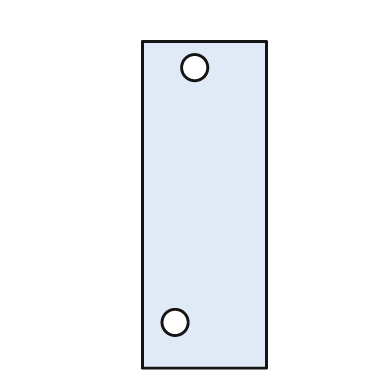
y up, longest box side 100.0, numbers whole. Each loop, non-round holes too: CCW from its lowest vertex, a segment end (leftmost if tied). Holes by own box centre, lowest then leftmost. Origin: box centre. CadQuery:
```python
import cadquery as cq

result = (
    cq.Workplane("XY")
    .moveTo(-19.0, -50.0)
    .lineTo(19.0, -50.0)
    .lineTo(19.0, 50.0)
    .lineTo(-19.0, 50.0)
    .close()
    .moveTo(-9.0, -36.0)
    .circle(4.0)
    .moveTo(-3.0, 42.0)
    .circle(4.0)
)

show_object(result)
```